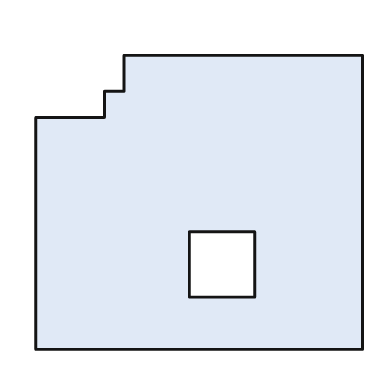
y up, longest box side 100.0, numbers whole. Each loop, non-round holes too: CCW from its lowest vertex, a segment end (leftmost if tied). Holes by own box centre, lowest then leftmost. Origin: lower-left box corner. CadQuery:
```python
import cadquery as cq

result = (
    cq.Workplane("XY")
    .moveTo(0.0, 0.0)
    .lineTo(100.0, 0.0)
    .lineTo(100.0, 90.0)
    .lineTo(27.0, 90.0)
    .lineTo(27.0, 79.0)
    .lineTo(21.0, 79.0)
    .lineTo(21.0, 71.0)
    .lineTo(0.0, 71.0)
    .close()
    .moveTo(47.0, 16.0)
    .lineTo(67.0, 16.0)
    .lineTo(67.0, 36.0)
    .lineTo(47.0, 36.0)
    .close()
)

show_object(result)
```